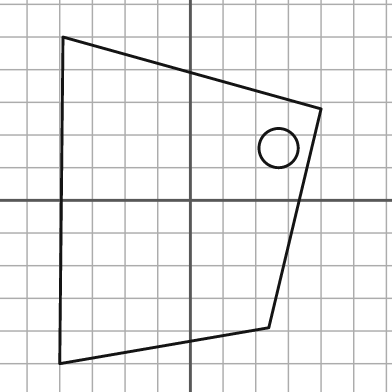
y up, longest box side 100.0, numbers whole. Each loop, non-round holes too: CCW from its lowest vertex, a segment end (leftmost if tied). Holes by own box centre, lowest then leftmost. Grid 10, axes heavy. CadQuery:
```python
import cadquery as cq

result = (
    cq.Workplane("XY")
    .moveTo(-40.0, -50.0)
    .lineTo(24.0, -39.0)
    .lineTo(40.0, 28.0)
    .lineTo(-39.0, 50.0)
    .close()
    .moveTo(27.0, 16.0)
    .circle(6.0)
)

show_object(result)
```